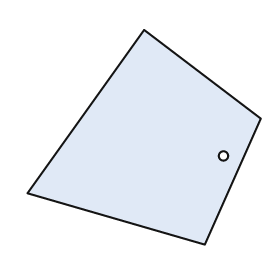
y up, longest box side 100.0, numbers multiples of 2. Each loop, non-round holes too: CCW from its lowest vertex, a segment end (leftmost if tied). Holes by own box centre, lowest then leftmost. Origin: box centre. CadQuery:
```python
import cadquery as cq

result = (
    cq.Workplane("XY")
    .moveTo(26.0, -46.0)
    .lineTo(50.0, 8.0)
    .lineTo(0.0, 46.0)
    .lineTo(-50.0, -24.0)
    .close()
    .moveTo(34.0, -8.0)
    .circle(2.0)
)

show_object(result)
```